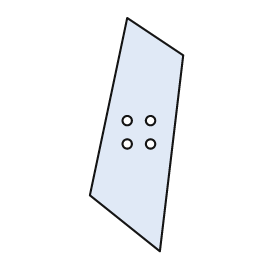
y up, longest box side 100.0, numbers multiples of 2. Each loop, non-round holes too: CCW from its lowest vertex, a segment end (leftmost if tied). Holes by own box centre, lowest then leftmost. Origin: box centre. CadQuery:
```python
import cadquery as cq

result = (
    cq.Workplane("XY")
    .moveTo(10.0, -50.0)
    .lineTo(20.0, 34.0)
    .lineTo(-4.0, 50.0)
    .lineTo(-20.0, -26.0)
    .close()
    .moveTo(-4.0, -4.0)
    .circle(2.0)
    .moveTo(6.0, -4.0)
    .circle(2.0)
    .moveTo(-4.0, 6.0)
    .circle(2.0)
    .moveTo(6.0, 6.0)
    .circle(2.0)
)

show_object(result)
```